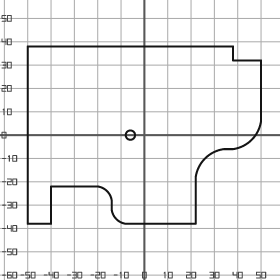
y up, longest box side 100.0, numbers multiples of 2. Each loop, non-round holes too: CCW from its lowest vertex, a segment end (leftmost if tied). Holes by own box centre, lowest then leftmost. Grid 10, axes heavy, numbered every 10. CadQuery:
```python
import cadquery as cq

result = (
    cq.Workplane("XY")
    .moveTo(-50.0, -38.0)
    .lineTo(-40.0, -38.0)
    .lineTo(-40.0, -22.0)
    .lineTo(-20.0, -22.0)
    .threePointArc((-16.0, -24.0), (-14.0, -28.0))
    .lineTo(-14.0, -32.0)
    .threePointArc((-12.0, -36.0), (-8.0, -38.0))
    .lineTo(22.0, -38.0)
    .lineTo(22.0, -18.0)
    .threePointArc((26.0, -10.0), (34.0, -6.0))
    .lineTo(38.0, -6.0)
    .threePointArc((46.0, -2.0), (50.0, 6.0))
    .lineTo(50.0, 32.0)
    .lineTo(38.0, 32.0)
    .lineTo(38.0, 38.0)
    .lineTo(-50.0, 38.0)
    .close()
    .moveTo(-6.0, 0.0)
    .circle(2.0)
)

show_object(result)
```